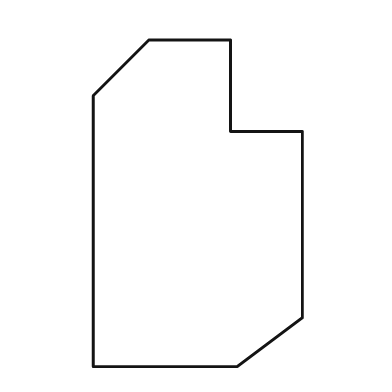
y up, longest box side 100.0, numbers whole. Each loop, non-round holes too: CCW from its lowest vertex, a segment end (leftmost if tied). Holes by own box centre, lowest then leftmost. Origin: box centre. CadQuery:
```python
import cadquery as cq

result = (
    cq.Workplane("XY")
    .moveTo(-32.0, -50.0)
    .lineTo(12.0, -50.0)
    .lineTo(32.0, -35.0)
    .lineTo(32.0, 22.0)
    .lineTo(10.0, 22.0)
    .lineTo(10.0, 50.0)
    .lineTo(-15.0, 50.0)
    .lineTo(-32.0, 33.0)
    .close()
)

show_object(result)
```